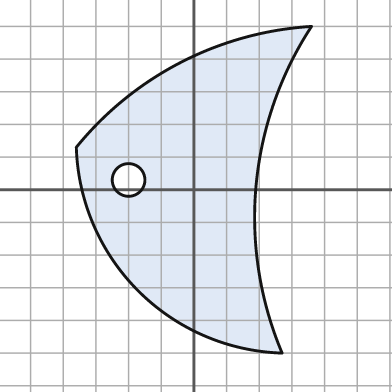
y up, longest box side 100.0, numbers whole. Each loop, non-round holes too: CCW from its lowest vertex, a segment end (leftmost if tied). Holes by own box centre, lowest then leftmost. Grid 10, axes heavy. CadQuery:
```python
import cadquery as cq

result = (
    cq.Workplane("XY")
    .moveTo(27.0, -50.0)
    .threePointArc((19.0, 1.0), (36.0, 50.0))
    .threePointArc((-4.0, 39.0), (-36.0, 13.0))
    .threePointArc((-17.0, -31.0), (27.0, -50.0))
    .close()
    .moveTo(-20.0, 3.0)
    .circle(5.0)
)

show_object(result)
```